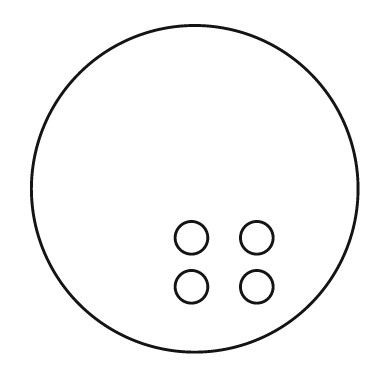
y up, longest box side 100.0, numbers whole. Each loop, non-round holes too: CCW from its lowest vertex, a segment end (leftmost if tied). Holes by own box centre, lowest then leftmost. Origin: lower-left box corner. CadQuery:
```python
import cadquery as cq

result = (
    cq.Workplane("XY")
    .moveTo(50.0, 50.0)
    .circle(50.0)
    .moveTo(49.0, 20.0)
    .circle(5.0)
    .moveTo(69.0, 20.0)
    .circle(5.0)
    .moveTo(49.0, 35.0)
    .circle(5.0)
    .moveTo(69.0, 35.0)
    .circle(5.0)
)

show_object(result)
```